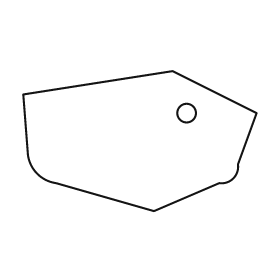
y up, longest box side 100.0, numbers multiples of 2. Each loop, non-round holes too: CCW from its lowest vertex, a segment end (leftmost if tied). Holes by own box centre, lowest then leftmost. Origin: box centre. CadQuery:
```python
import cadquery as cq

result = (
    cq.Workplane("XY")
    .moveTo(6.0, -30.0)
    .lineTo(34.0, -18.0)
    .threePointArc((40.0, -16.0), (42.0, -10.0))
    .lineTo(50.0, 12.0)
    .lineTo(14.0, 30.0)
    .lineTo(-50.0, 20.0)
    .lineTo(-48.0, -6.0)
    .threePointArc((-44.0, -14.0), (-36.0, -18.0))
    .close()
    .moveTo(20.0, 12.0)
    .circle(4.0)
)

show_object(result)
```